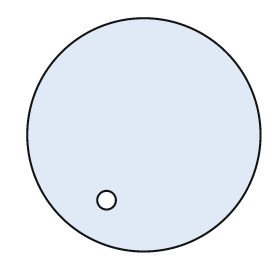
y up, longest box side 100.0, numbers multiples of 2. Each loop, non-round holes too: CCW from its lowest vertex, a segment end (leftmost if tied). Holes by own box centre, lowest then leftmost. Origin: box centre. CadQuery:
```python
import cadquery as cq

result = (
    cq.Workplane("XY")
    .moveTo(0.0, 0.0)
    .circle(50.0)
    .moveTo(-16.0, -28.0)
    .circle(4.0)
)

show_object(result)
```